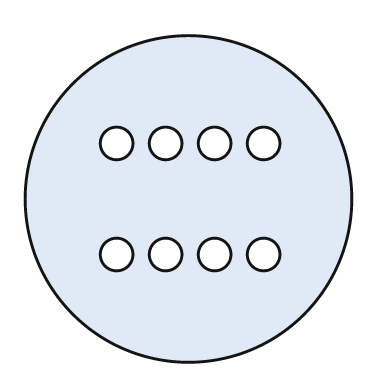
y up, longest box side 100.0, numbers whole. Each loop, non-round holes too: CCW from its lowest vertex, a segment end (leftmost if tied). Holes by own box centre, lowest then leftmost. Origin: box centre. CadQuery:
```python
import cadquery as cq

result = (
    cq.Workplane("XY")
    .moveTo(0.0, 0.0)
    .circle(50.0)
    .moveTo(-22.0, -17.0)
    .circle(5.0)
    .moveTo(-7.0, -17.0)
    .circle(5.0)
    .moveTo(8.0, -17.0)
    .circle(5.0)
    .moveTo(23.0, -17.0)
    .circle(5.0)
    .moveTo(-22.0, 17.0)
    .circle(5.0)
    .moveTo(-7.0, 17.0)
    .circle(5.0)
    .moveTo(8.0, 17.0)
    .circle(5.0)
    .moveTo(23.0, 17.0)
    .circle(5.0)
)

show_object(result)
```